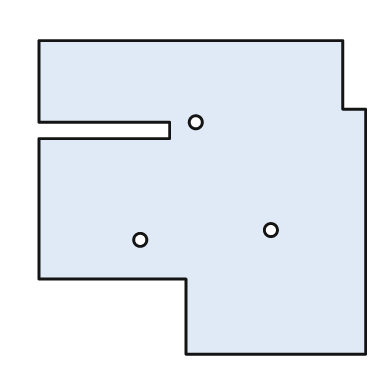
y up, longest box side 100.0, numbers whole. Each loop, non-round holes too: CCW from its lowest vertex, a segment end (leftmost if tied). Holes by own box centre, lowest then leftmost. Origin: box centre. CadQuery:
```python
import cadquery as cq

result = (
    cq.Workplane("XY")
    .moveTo(-5.0, -48.0)
    .lineTo(50.0, -48.0)
    .lineTo(50.0, 27.0)
    .lineTo(43.0, 27.0)
    .lineTo(43.0, 48.0)
    .lineTo(-50.0, 48.0)
    .lineTo(-50.0, 23.0)
    .lineTo(-10.0, 23.0)
    .lineTo(-10.0, 18.0)
    .lineTo(-50.0, 18.0)
    .lineTo(-50.0, -25.0)
    .lineTo(-5.0, -25.0)
    .close()
    .moveTo(-19.0, -13.0)
    .circle(2.0)
    .moveTo(21.0, -10.0)
    .circle(2.0)
    .moveTo(-2.0, 23.0)
    .circle(2.0)
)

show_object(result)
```